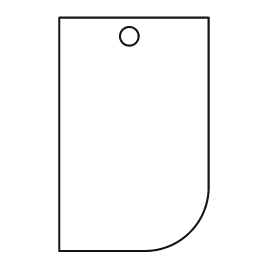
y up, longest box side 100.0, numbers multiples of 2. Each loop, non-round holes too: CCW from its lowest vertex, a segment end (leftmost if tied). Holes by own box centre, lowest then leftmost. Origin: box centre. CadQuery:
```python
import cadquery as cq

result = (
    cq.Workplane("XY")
    .moveTo(-32.0, -50.0)
    .lineTo(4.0, -50.0)
    .threePointArc((24.0, -42.0), (32.0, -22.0))
    .lineTo(32.0, 50.0)
    .lineTo(-32.0, 50.0)
    .close()
    .moveTo(-2.0, 42.0)
    .circle(4.0)
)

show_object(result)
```